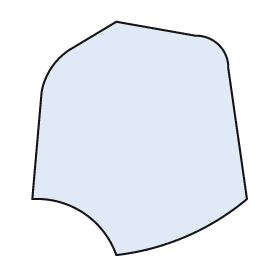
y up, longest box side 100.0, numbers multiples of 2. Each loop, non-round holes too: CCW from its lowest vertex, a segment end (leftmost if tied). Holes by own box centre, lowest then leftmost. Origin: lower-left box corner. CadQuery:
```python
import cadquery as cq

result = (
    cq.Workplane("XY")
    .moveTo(36.0, 0.0)
    .threePointArc((66.0, 8.0), (92.0, 24.0))
    .lineTo(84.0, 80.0)
    .threePointArc((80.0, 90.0), (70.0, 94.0))
    .lineTo(36.0, 100.0)
    .lineTo(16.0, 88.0)
    .threePointArc((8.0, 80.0), (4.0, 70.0))
    .lineTo(0.0, 24.0)
    .threePointArc((22.0, 18.0), (36.0, 0.0))
    .close()
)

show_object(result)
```